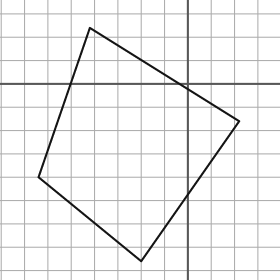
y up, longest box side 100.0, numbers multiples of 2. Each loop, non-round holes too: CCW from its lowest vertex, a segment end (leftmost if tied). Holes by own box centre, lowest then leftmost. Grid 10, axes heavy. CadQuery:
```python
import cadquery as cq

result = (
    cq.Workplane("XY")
    .moveTo(-20.0, -76.0)
    .lineTo(22.0, -16.0)
    .lineTo(-42.0, 24.0)
    .lineTo(-64.0, -40.0)
    .close()
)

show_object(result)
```